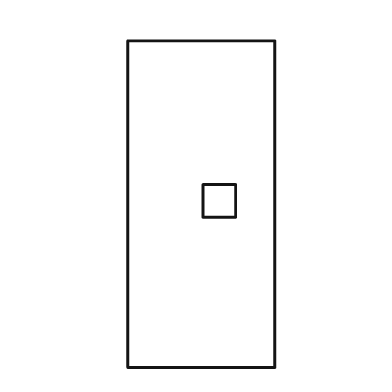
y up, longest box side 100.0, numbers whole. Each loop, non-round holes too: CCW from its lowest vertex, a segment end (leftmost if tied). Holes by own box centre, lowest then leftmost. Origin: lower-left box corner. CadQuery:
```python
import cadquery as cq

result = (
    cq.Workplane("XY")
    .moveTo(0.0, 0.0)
    .lineTo(45.0, 0.0)
    .lineTo(45.0, 100.0)
    .lineTo(0.0, 100.0)
    .close()
    .moveTo(23.0, 46.0)
    .lineTo(33.0, 46.0)
    .lineTo(33.0, 56.0)
    .lineTo(23.0, 56.0)
    .close()
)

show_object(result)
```